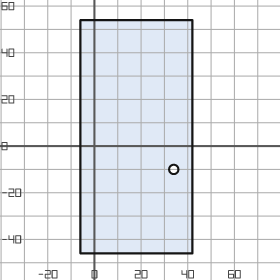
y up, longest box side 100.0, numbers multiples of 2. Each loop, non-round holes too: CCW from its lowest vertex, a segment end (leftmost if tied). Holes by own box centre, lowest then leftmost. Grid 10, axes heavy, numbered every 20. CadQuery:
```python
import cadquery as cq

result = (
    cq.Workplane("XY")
    .moveTo(-6.0, -46.0)
    .lineTo(42.0, -46.0)
    .lineTo(42.0, 54.0)
    .lineTo(-6.0, 54.0)
    .close()
    .moveTo(34.0, -10.0)
    .circle(2.0)
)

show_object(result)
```